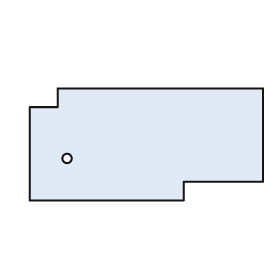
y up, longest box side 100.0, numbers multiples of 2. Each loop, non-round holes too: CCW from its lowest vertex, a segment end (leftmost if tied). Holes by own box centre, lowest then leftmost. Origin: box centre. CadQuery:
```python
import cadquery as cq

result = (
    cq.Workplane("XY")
    .moveTo(-50.0, -24.0)
    .lineTo(16.0, -24.0)
    .lineTo(16.0, -16.0)
    .lineTo(50.0, -16.0)
    .lineTo(50.0, 24.0)
    .lineTo(-38.0, 24.0)
    .lineTo(-38.0, 16.0)
    .lineTo(-50.0, 16.0)
    .close()
    .moveTo(-34.0, -6.0)
    .circle(2.0)
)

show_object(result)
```